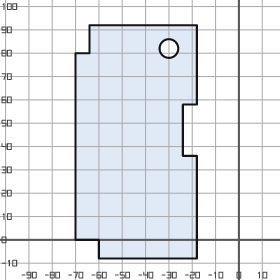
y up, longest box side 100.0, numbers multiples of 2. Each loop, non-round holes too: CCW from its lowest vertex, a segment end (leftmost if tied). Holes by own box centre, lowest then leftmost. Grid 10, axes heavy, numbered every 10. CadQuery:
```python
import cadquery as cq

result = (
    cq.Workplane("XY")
    .moveTo(-60.0, -8.0)
    .lineTo(-18.0, -8.0)
    .lineTo(-18.0, 36.0)
    .lineTo(-24.0, 36.0)
    .lineTo(-24.0, 58.0)
    .lineTo(-18.0, 58.0)
    .lineTo(-18.0, 92.0)
    .lineTo(-64.0, 92.0)
    .lineTo(-64.0, 80.0)
    .lineTo(-70.0, 80.0)
    .lineTo(-70.0, 0.0)
    .lineTo(-60.0, 0.0)
    .close()
    .moveTo(-30.0, 82.0)
    .circle(4.0)
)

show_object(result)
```